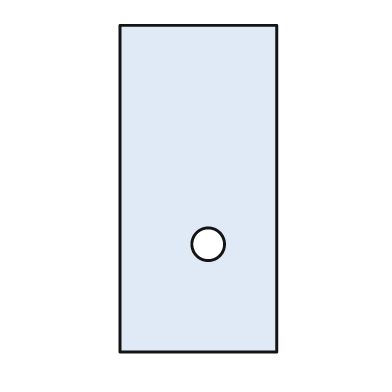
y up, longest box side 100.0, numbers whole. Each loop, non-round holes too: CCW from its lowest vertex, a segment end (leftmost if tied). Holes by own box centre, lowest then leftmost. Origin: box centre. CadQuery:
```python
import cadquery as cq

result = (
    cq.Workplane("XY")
    .moveTo(-24.0, -50.0)
    .lineTo(24.0, -50.0)
    .lineTo(24.0, 50.0)
    .lineTo(-24.0, 50.0)
    .close()
    .moveTo(3.0, -17.0)
    .circle(5.0)
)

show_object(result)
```